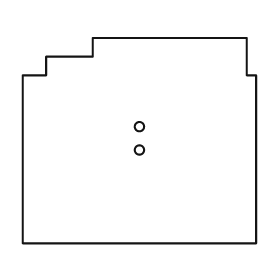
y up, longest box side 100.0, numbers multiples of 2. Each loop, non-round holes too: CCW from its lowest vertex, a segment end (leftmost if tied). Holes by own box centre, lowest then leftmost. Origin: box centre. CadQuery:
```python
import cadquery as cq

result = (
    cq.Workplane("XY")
    .moveTo(-50.0, -44.0)
    .lineTo(50.0, -44.0)
    .lineTo(50.0, 28.0)
    .lineTo(46.0, 28.0)
    .lineTo(46.0, 44.0)
    .lineTo(-20.0, 44.0)
    .lineTo(-20.0, 36.0)
    .lineTo(-40.0, 36.0)
    .lineTo(-40.0, 28.0)
    .lineTo(-50.0, 28.0)
    .close()
    .moveTo(0.0, -4.0)
    .circle(2.0)
    .moveTo(0.0, 6.0)
    .circle(2.0)
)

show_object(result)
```